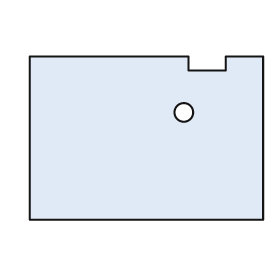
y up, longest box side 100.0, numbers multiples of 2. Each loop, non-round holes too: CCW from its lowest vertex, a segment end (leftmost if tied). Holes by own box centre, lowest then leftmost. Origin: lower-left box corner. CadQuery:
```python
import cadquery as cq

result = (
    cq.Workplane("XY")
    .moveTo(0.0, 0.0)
    .lineTo(100.0, 0.0)
    .lineTo(100.0, 70.0)
    .lineTo(84.0, 70.0)
    .lineTo(84.0, 64.0)
    .lineTo(68.0, 64.0)
    .lineTo(68.0, 70.0)
    .lineTo(0.0, 70.0)
    .close()
    .moveTo(66.0, 46.0)
    .circle(4.0)
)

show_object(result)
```